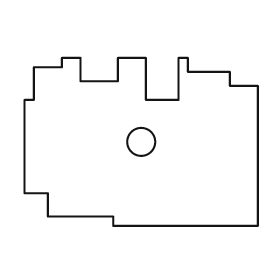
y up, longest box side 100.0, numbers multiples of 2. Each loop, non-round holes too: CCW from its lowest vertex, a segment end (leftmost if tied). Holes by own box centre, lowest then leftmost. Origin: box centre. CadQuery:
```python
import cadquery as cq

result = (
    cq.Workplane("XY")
    .moveTo(-12.0, -36.0)
    .lineTo(50.0, -36.0)
    .lineTo(50.0, 24.0)
    .lineTo(38.0, 24.0)
    .lineTo(38.0, 30.0)
    .lineTo(20.0, 30.0)
    .lineTo(20.0, 36.0)
    .lineTo(16.0, 36.0)
    .lineTo(16.0, 18.0)
    .lineTo(2.0, 18.0)
    .lineTo(2.0, 36.0)
    .lineTo(-10.0, 36.0)
    .lineTo(-10.0, 26.0)
    .lineTo(-26.0, 26.0)
    .lineTo(-26.0, 36.0)
    .lineTo(-34.0, 36.0)
    .lineTo(-34.0, 32.0)
    .lineTo(-46.0, 32.0)
    .lineTo(-46.0, 18.0)
    .lineTo(-50.0, 18.0)
    .lineTo(-50.0, -22.0)
    .lineTo(-40.0, -22.0)
    .lineTo(-40.0, -32.0)
    .lineTo(-12.0, -32.0)
    .close()
    .moveTo(0.0, 0.0)
    .circle(6.0)
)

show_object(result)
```